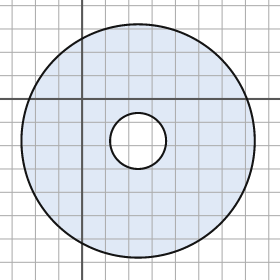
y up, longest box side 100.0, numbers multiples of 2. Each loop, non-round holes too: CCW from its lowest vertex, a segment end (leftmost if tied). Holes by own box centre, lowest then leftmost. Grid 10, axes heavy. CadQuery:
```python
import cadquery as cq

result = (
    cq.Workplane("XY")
    .moveTo(24.0, -18.0)
    .circle(50.0)
    .moveTo(24.0, -18.0)
    .circle(12.0)
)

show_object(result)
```